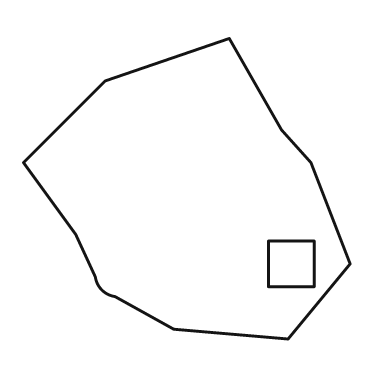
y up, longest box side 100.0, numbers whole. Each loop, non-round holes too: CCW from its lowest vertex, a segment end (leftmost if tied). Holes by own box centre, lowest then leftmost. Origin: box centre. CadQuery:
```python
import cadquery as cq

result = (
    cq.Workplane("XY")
    .moveTo(31.0, -46.0)
    .lineTo(50.0, -23.0)
    .lineTo(38.0, 8.0)
    .lineTo(29.0, 18.0)
    .lineTo(13.0, 46.0)
    .lineTo(-25.0, 33.0)
    .lineTo(-50.0, 8.0)
    .lineTo(-34.0, -14.0)
    .lineTo(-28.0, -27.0)
    .threePointArc((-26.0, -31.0), (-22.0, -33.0))
    .lineTo(-4.0, -43.0)
    .close()
    .moveTo(25.0, -30.0)
    .lineTo(39.0, -30.0)
    .lineTo(39.0, -16.0)
    .lineTo(25.0, -16.0)
    .close()
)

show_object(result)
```